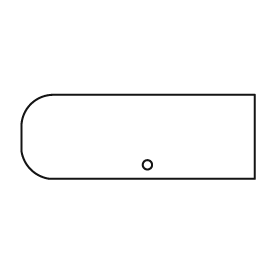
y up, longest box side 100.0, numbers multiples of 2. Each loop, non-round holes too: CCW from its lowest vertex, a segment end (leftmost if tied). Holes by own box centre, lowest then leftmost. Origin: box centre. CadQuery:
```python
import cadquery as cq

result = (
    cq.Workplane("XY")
    .moveTo(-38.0, -18.0)
    .lineTo(50.0, -18.0)
    .lineTo(50.0, 18.0)
    .lineTo(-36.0, 18.0)
    .threePointArc((-46.0, 14.0), (-50.0, 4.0))
    .lineTo(-50.0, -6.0)
    .threePointArc((-46.0, -14.0), (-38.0, -18.0))
    .close()
    .moveTo(4.0, -12.0)
    .circle(2.0)
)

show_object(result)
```